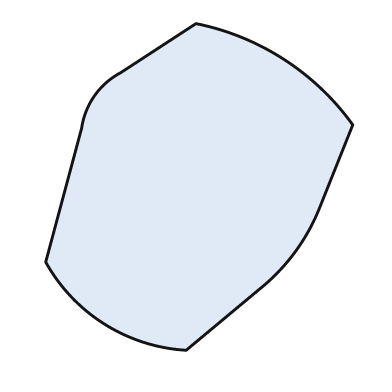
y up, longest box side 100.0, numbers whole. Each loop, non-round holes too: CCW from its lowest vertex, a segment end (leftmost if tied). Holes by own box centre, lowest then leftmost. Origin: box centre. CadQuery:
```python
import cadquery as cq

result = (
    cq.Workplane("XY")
    .moveTo(-4.0, -50.0)
    .lineTo(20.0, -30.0)
    .threePointArc((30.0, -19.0), (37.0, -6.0))
    .lineTo(47.0, 19.0)
    .threePointArc((26.0, 39.0), (-1.0, 50.0))
    .lineTo(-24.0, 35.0)
    .threePointArc((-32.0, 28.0), (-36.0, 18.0))
    .lineTo(-47.0, -23.0)
    .threePointArc((-29.0, -42.0), (-4.0, -50.0))
    .close()
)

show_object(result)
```